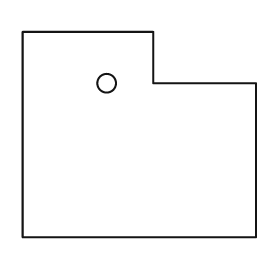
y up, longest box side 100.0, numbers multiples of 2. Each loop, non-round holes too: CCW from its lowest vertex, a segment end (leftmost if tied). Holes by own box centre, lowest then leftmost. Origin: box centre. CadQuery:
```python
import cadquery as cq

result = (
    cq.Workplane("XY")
    .moveTo(-50.0, -44.0)
    .lineTo(50.0, -44.0)
    .lineTo(50.0, 22.0)
    .lineTo(6.0, 22.0)
    .lineTo(6.0, 44.0)
    .lineTo(-50.0, 44.0)
    .close()
    .moveTo(-14.0, 22.0)
    .circle(4.0)
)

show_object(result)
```